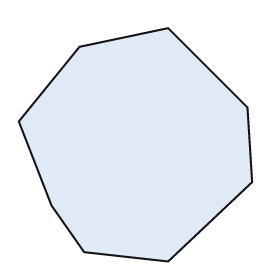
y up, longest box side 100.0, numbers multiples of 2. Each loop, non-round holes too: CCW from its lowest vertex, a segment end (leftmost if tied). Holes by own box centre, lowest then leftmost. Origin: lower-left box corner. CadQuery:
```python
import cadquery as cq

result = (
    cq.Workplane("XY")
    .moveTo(64.0, 0.0)
    .lineTo(100.0, 34.0)
    .lineTo(98.0, 66.0)
    .lineTo(64.0, 100.0)
    .lineTo(26.0, 92.0)
    .lineTo(0.0, 60.0)
    .lineTo(14.0, 24.0)
    .lineTo(28.0, 4.0)
    .close()
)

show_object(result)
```